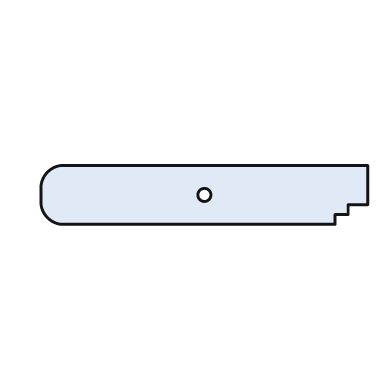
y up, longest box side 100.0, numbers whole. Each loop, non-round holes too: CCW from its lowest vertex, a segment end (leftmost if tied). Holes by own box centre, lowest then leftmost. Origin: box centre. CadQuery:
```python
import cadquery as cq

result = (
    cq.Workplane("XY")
    .moveTo(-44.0, -9.0)
    .lineTo(40.0, -9.0)
    .lineTo(40.0, -6.0)
    .lineTo(44.0, -6.0)
    .lineTo(44.0, -3.0)
    .lineTo(50.0, -3.0)
    .lineTo(50.0, 9.0)
    .lineTo(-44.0, 9.0)
    .threePointArc((-48.0, 7.0), (-50.0, 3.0))
    .lineTo(-50.0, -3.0)
    .threePointArc((-48.0, -7.0), (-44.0, -9.0))
    .close()
    .moveTo(0.0, 0.0)
    .circle(2.0)
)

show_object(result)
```